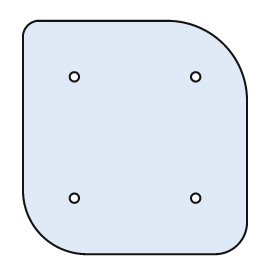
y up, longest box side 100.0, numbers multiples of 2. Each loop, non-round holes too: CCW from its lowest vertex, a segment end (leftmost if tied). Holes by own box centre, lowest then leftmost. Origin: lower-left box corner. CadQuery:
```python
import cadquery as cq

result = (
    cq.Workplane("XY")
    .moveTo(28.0, 0.0)
    .lineTo(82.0, 0.0)
    .threePointArc((92.0, 4.0), (96.0, 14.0))
    .lineTo(96.0, 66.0)
    .threePointArc((86.0, 90.0), (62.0, 100.0))
    .lineTo(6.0, 100.0)
    .threePointArc((2.0, 98.0), (0.0, 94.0))
    .lineTo(0.0, 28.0)
    .threePointArc((8.0, 8.0), (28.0, 0.0))
    .close()
    .moveTo(22.0, 24.0)
    .circle(2.0)
    .moveTo(74.0, 24.0)
    .circle(2.0)
    .moveTo(22.0, 76.0)
    .circle(2.0)
    .moveTo(74.0, 76.0)
    .circle(2.0)
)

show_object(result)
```